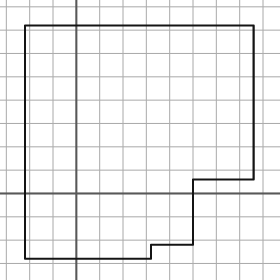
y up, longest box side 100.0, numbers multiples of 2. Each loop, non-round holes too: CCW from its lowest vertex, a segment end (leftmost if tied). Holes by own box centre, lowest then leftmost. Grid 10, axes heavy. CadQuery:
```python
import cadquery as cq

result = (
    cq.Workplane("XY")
    .moveTo(-22.0, -28.0)
    .lineTo(32.0, -28.0)
    .lineTo(32.0, -22.0)
    .lineTo(50.0, -22.0)
    .lineTo(50.0, 6.0)
    .lineTo(76.0, 6.0)
    .lineTo(76.0, 72.0)
    .lineTo(-22.0, 72.0)
    .close()
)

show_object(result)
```